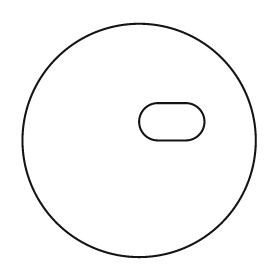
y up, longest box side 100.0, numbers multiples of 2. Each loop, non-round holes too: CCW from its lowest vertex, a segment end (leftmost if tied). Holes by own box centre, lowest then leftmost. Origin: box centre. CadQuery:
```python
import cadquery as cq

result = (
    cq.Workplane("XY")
    .moveTo(0.0, 0.0)
    .circle(50.0)
    .moveTo(8.0, 0.0)
    .lineTo(20.0, 0.0)
    .threePointArc((28.0, 8.0), (20.0, 16.0))
    .lineTo(8.0, 16.0)
    .threePointArc((0.0, 8.0), (8.0, 0.0))
    .close()
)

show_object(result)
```